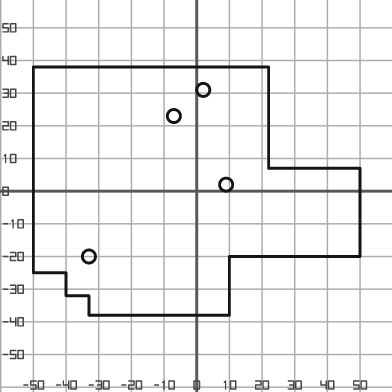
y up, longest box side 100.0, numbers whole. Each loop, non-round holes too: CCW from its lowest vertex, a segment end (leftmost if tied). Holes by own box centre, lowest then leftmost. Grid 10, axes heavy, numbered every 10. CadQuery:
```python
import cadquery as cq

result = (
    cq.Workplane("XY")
    .moveTo(-33.0, -38.0)
    .lineTo(10.0, -38.0)
    .lineTo(10.0, -20.0)
    .lineTo(50.0, -20.0)
    .lineTo(50.0, 7.0)
    .lineTo(22.0, 7.0)
    .lineTo(22.0, 38.0)
    .lineTo(-50.0, 38.0)
    .lineTo(-50.0, -25.0)
    .lineTo(-40.0, -25.0)
    .lineTo(-40.0, -32.0)
    .lineTo(-33.0, -32.0)
    .close()
    .moveTo(-33.0, -20.0)
    .circle(2.0)
    .moveTo(9.0, 2.0)
    .circle(2.0)
    .moveTo(-7.0, 23.0)
    .circle(2.0)
    .moveTo(2.0, 31.0)
    .circle(2.0)
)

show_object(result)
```